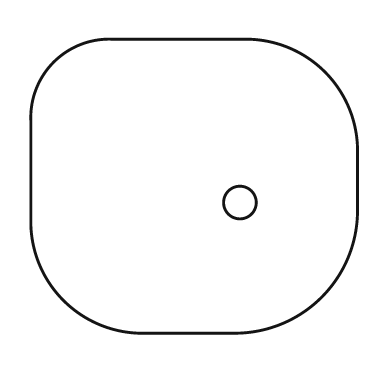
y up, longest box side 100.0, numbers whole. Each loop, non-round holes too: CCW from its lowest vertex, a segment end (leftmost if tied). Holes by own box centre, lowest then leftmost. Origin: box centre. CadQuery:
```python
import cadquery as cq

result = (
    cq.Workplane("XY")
    .moveTo(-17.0, -45.0)
    .lineTo(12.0, -45.0)
    .threePointArc((39.0, -34.0), (50.0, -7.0))
    .lineTo(50.0, 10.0)
    .threePointArc((40.0, 35.0), (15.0, 45.0))
    .lineTo(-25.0, 45.0)
    .threePointArc((-43.0, 38.0), (-50.0, 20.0))
    .lineTo(-50.0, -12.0)
    .threePointArc((-40.0, -35.0), (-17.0, -45.0))
    .close()
    .moveTo(14.0, -5.0)
    .circle(5.0)
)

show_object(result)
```